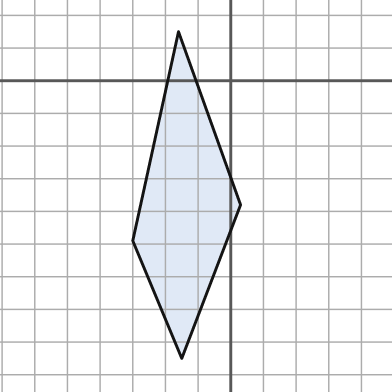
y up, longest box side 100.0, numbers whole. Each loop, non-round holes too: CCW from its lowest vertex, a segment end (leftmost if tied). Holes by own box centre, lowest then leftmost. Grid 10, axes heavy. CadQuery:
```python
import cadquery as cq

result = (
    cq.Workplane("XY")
    .moveTo(-15.0, -85.0)
    .lineTo(3.0, -38.0)
    .lineTo(-16.0, 15.0)
    .lineTo(-30.0, -49.0)
    .close()
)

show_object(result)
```